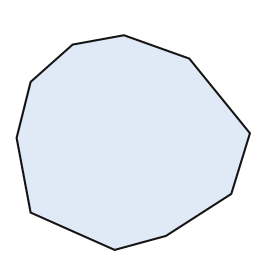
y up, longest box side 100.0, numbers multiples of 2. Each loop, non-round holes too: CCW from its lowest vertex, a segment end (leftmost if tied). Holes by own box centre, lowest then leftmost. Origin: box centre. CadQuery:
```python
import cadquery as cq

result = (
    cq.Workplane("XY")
    .moveTo(-8.0, -46.0)
    .lineTo(14.0, -40.0)
    .lineTo(42.0, -22.0)
    .lineTo(50.0, 4.0)
    .lineTo(24.0, 36.0)
    .lineTo(-4.0, 46.0)
    .lineTo(-26.0, 42.0)
    .lineTo(-44.0, 26.0)
    .lineTo(-50.0, 2.0)
    .lineTo(-44.0, -30.0)
    .close()
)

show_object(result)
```